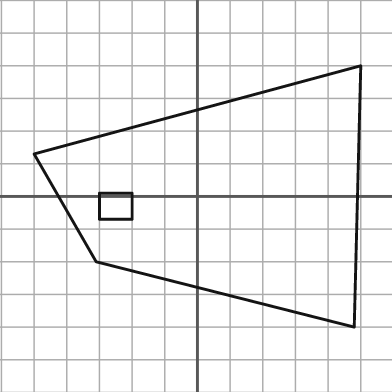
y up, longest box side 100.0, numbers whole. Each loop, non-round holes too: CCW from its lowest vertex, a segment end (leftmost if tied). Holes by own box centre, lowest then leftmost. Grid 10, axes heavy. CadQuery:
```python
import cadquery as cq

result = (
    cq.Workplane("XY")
    .moveTo(48.0, -40.0)
    .lineTo(50.0, 40.0)
    .lineTo(-50.0, 13.0)
    .lineTo(-31.0, -20.0)
    .close()
    .moveTo(-30.0, -7.0)
    .lineTo(-20.0, -7.0)
    .lineTo(-20.0, 1.0)
    .lineTo(-30.0, 1.0)
    .close()
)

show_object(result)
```